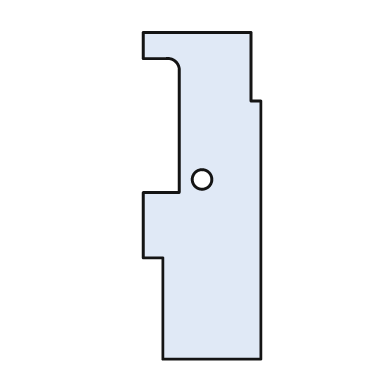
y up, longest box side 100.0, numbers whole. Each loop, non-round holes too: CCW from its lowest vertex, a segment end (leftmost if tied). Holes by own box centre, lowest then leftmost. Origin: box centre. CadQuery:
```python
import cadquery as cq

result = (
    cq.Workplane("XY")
    .moveTo(-12.0, -50.0)
    .lineTo(18.0, -50.0)
    .lineTo(18.0, 29.0)
    .lineTo(15.0, 29.0)
    .lineTo(15.0, 50.0)
    .lineTo(-18.0, 50.0)
    .lineTo(-18.0, 42.0)
    .lineTo(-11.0, 42.0)
    .threePointArc((-8.0, 41.0), (-7.0, 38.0))
    .lineTo(-7.0, 1.0)
    .lineTo(-18.0, 1.0)
    .lineTo(-18.0, -19.0)
    .lineTo(-12.0, -19.0)
    .close()
    .moveTo(0.0, 5.0)
    .circle(3.0)
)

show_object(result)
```